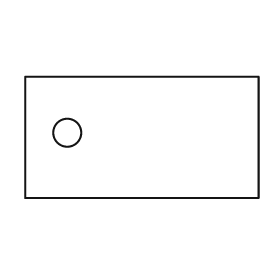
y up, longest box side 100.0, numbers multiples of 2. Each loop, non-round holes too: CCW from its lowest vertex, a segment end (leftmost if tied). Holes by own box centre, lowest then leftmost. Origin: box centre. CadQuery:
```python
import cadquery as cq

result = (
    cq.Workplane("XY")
    .moveTo(-50.0, -26.0)
    .lineTo(50.0, -26.0)
    .lineTo(50.0, 26.0)
    .lineTo(-50.0, 26.0)
    .close()
    .moveTo(-32.0, 2.0)
    .circle(6.0)
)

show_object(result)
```